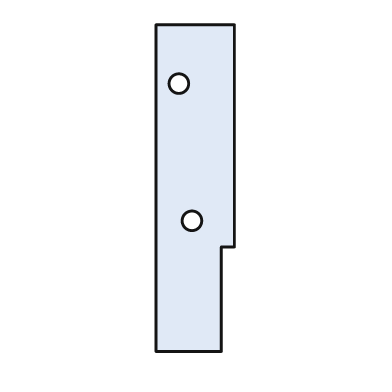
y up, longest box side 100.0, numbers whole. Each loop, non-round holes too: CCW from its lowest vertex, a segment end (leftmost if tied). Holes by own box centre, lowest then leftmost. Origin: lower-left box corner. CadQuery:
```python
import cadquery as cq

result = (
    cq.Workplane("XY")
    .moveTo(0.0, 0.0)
    .lineTo(20.0, 0.0)
    .lineTo(20.0, 32.0)
    .lineTo(24.0, 32.0)
    .lineTo(24.0, 100.0)
    .lineTo(0.0, 100.0)
    .close()
    .moveTo(11.0, 40.0)
    .circle(3.0)
    .moveTo(7.0, 82.0)
    .circle(3.0)
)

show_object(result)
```